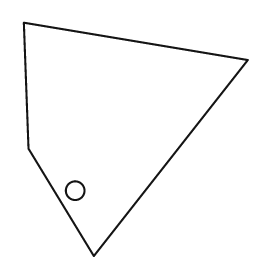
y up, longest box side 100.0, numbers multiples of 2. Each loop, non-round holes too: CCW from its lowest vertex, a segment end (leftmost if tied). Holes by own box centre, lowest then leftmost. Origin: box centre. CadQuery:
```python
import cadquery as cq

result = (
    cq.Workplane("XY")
    .moveTo(-18.0, -50.0)
    .lineTo(48.0, 34.0)
    .lineTo(-48.0, 50.0)
    .lineTo(-46.0, -4.0)
    .close()
    .moveTo(-26.0, -22.0)
    .circle(4.0)
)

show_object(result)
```